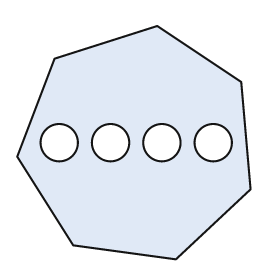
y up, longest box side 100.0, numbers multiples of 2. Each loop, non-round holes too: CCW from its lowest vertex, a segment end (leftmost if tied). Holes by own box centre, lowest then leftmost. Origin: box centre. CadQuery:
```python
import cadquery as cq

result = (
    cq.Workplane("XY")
    .moveTo(18.0, -50.0)
    .lineTo(50.0, -20.0)
    .lineTo(46.0, 26.0)
    .lineTo(10.0, 50.0)
    .lineTo(-34.0, 36.0)
    .lineTo(-50.0, -6.0)
    .lineTo(-26.0, -44.0)
    .close()
    .moveTo(-32.0, 0.0)
    .circle(8.0)
    .moveTo(-10.0, 0.0)
    .circle(8.0)
    .moveTo(12.0, 0.0)
    .circle(8.0)
    .moveTo(34.0, 0.0)
    .circle(8.0)
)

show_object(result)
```